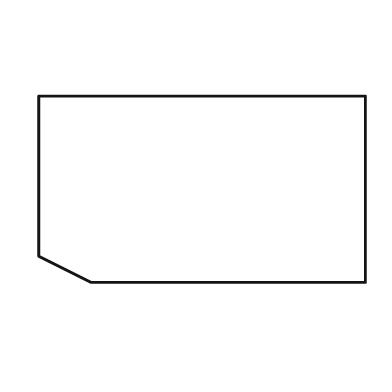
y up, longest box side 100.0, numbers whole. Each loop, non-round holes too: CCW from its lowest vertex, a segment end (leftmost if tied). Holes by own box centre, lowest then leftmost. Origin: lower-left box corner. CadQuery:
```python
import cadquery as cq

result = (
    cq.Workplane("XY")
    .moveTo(16.0, 0.0)
    .lineTo(100.0, 0.0)
    .lineTo(100.0, 57.0)
    .lineTo(0.0, 57.0)
    .lineTo(0.0, 8.0)
    .close()
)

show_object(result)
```